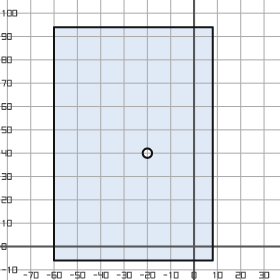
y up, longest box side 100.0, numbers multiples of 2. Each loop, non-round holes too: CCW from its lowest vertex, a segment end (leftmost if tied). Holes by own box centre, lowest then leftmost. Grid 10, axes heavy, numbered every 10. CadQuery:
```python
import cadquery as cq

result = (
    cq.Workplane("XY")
    .moveTo(-60.0, -6.0)
    .lineTo(8.0, -6.0)
    .lineTo(8.0, 94.0)
    .lineTo(-60.0, 94.0)
    .close()
    .moveTo(-20.0, 40.0)
    .circle(2.0)
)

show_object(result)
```